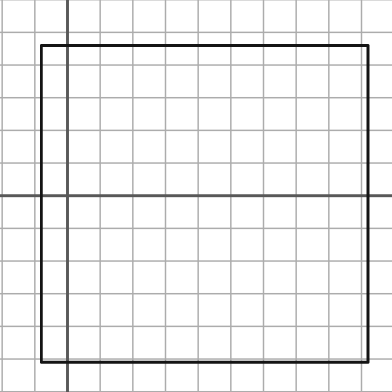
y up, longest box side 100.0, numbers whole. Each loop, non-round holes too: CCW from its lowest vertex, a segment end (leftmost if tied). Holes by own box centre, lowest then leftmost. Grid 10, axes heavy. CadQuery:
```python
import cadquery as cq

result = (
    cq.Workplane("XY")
    .moveTo(-8.0, -51.0)
    .lineTo(92.0, -51.0)
    .lineTo(92.0, 46.0)
    .lineTo(-8.0, 46.0)
    .close()
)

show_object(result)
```